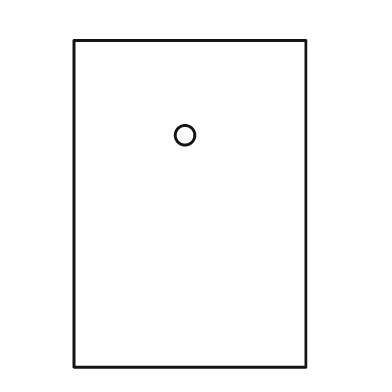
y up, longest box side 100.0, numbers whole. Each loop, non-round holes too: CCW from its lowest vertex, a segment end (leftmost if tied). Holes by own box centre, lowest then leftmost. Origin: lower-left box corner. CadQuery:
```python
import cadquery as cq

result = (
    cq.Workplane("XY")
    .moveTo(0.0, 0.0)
    .lineTo(71.0, 0.0)
    .lineTo(71.0, 100.0)
    .lineTo(0.0, 100.0)
    .close()
    .moveTo(34.0, 71.0)
    .circle(3.0)
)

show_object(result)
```